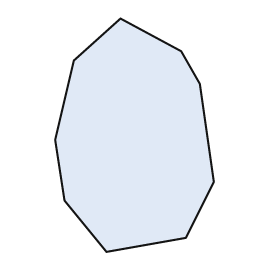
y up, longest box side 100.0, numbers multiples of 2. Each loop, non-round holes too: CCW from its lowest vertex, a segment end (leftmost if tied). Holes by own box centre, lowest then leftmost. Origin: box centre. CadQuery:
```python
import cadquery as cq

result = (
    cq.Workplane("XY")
    .moveTo(-12.0, -50.0)
    .lineTo(22.0, -44.0)
    .lineTo(34.0, -20.0)
    .lineTo(28.0, 22.0)
    .lineTo(20.0, 36.0)
    .lineTo(-6.0, 50.0)
    .lineTo(-26.0, 32.0)
    .lineTo(-34.0, -2.0)
    .lineTo(-30.0, -28.0)
    .close()
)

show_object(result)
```